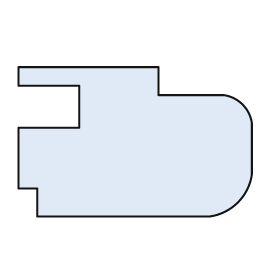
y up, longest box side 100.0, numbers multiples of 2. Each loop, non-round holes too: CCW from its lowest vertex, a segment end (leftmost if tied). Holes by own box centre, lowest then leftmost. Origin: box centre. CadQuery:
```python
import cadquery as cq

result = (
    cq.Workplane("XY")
    .moveTo(-42.0, -32.0)
    .lineTo(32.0, -32.0)
    .threePointArc((44.0, -26.0), (50.0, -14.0))
    .lineTo(50.0, 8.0)
    .threePointArc((46.0, 16.0), (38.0, 20.0))
    .lineTo(10.0, 20.0)
    .lineTo(10.0, 32.0)
    .lineTo(-50.0, 32.0)
    .lineTo(-50.0, 24.0)
    .lineTo(-24.0, 24.0)
    .lineTo(-24.0, 6.0)
    .lineTo(-50.0, 6.0)
    .lineTo(-50.0, -20.0)
    .lineTo(-42.0, -20.0)
    .close()
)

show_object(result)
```